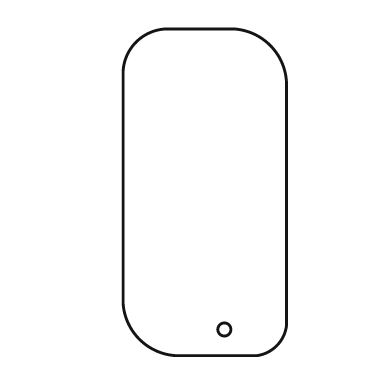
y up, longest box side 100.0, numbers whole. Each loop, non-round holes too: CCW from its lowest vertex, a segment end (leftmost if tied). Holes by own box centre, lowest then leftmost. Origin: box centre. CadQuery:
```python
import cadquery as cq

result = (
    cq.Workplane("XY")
    .moveTo(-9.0, -50.0)
    .lineTo(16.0, -50.0)
    .threePointArc((22.0, -47.0), (25.0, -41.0))
    .lineTo(25.0, 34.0)
    .threePointArc((20.0, 45.0), (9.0, 50.0))
    .lineTo(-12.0, 50.0)
    .threePointArc((-21.0, 46.0), (-25.0, 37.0))
    .lineTo(-25.0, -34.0)
    .threePointArc((-20.0, -45.0), (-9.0, -50.0))
    .close()
    .moveTo(6.0, -42.0)
    .circle(2.0)
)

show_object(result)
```